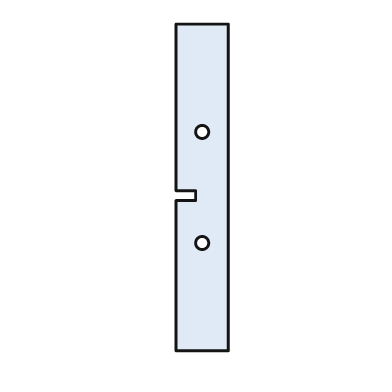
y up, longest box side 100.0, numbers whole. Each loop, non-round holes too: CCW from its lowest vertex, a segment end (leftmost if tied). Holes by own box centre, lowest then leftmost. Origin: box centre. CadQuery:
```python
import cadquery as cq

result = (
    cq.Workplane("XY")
    .moveTo(-8.0, -50.0)
    .lineTo(8.0, -50.0)
    .lineTo(8.0, 50.0)
    .lineTo(-8.0, 50.0)
    .lineTo(-8.0, -1.0)
    .lineTo(-2.0, -1.0)
    .lineTo(-2.0, -4.0)
    .lineTo(-8.0, -4.0)
    .close()
    .moveTo(0.0, -17.0)
    .circle(2.0)
    .moveTo(0.0, 17.0)
    .circle(2.0)
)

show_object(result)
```